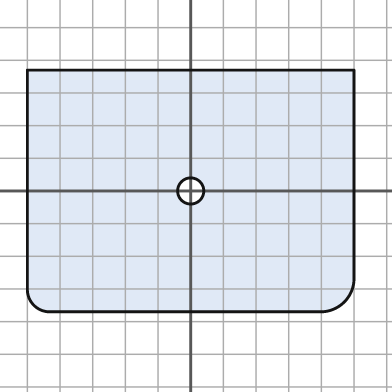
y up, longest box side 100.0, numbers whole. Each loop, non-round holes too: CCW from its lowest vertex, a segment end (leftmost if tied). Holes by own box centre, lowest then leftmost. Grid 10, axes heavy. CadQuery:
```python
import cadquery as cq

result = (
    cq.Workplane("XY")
    .moveTo(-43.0, -37.0)
    .lineTo(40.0, -37.0)
    .threePointArc((47.0, -34.0), (50.0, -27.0))
    .lineTo(50.0, 37.0)
    .lineTo(-50.0, 37.0)
    .lineTo(-50.0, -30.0)
    .threePointArc((-48.0, -35.0), (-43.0, -37.0))
    .close()
    .moveTo(0.0, 0.0)
    .circle(4.0)
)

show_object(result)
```